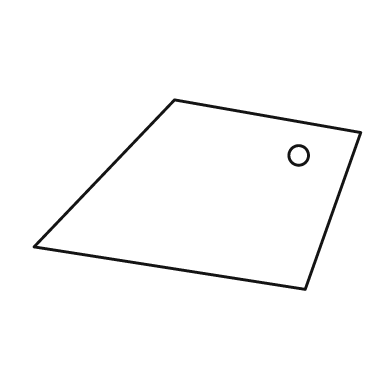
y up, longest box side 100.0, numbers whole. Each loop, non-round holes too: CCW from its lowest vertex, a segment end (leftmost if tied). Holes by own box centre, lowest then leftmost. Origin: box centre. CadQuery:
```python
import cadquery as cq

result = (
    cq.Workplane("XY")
    .moveTo(33.0, -29.0)
    .lineTo(50.0, 19.0)
    .lineTo(-7.0, 29.0)
    .lineTo(-50.0, -16.0)
    .close()
    .moveTo(31.0, 12.0)
    .circle(3.0)
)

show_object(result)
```